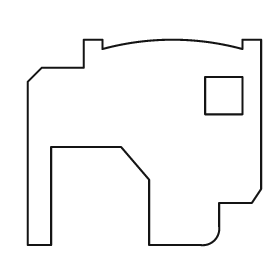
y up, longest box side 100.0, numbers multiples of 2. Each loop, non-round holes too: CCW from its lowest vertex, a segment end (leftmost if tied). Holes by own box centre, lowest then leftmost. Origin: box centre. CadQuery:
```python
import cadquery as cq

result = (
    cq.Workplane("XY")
    .moveTo(-50.0, -44.0)
    .lineTo(-40.0, -44.0)
    .lineTo(-40.0, -2.0)
    .lineTo(-10.0, -2.0)
    .lineTo(2.0, -16.0)
    .lineTo(2.0, -44.0)
    .lineTo(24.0, -44.0)
    .threePointArc((30.0, -42.0), (32.0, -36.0))
    .lineTo(32.0, -26.0)
    .lineTo(46.0, -26.0)
    .lineTo(50.0, -20.0)
    .lineTo(50.0, 44.0)
    .lineTo(42.0, 44.0)
    .lineTo(42.0, 40.0)
    .threePointArc((12.0, 44.0), (-18.0, 40.0))
    .lineTo(-18.0, 44.0)
    .lineTo(-26.0, 44.0)
    .lineTo(-26.0, 32.0)
    .lineTo(-44.0, 32.0)
    .lineTo(-50.0, 26.0)
    .close()
    .moveTo(26.0, 12.0)
    .lineTo(42.0, 12.0)
    .lineTo(42.0, 28.0)
    .lineTo(26.0, 28.0)
    .close()
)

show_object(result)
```